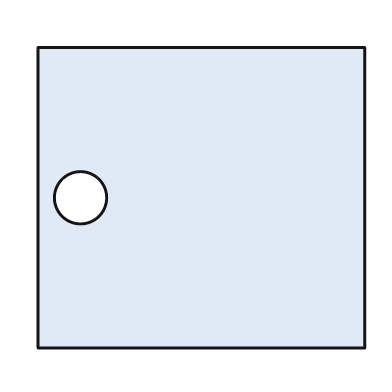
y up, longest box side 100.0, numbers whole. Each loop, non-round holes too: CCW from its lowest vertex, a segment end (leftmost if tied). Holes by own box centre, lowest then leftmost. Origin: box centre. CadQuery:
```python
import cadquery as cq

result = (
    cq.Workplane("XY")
    .moveTo(-50.0, -46.0)
    .lineTo(50.0, -46.0)
    .lineTo(50.0, 46.0)
    .lineTo(-50.0, 46.0)
    .close()
    .moveTo(-37.0, 0.0)
    .circle(8.0)
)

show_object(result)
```